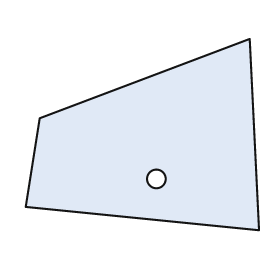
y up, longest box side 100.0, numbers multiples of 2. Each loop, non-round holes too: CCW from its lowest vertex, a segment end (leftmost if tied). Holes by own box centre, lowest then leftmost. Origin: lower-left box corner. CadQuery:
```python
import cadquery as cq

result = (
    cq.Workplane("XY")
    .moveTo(100.0, 0.0)
    .lineTo(96.0, 82.0)
    .lineTo(6.0, 48.0)
    .lineTo(0.0, 10.0)
    .close()
    .moveTo(56.0, 22.0)
    .circle(4.0)
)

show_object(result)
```